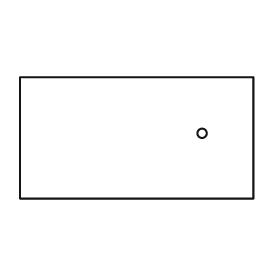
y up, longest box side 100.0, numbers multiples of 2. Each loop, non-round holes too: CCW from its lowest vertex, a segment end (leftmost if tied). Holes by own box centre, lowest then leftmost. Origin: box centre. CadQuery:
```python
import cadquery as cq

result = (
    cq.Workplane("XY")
    .moveTo(-50.0, -26.0)
    .lineTo(50.0, -26.0)
    .lineTo(50.0, 26.0)
    .lineTo(-50.0, 26.0)
    .close()
    .moveTo(28.0, 2.0)
    .circle(2.0)
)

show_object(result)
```